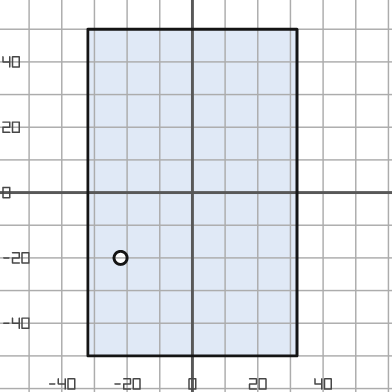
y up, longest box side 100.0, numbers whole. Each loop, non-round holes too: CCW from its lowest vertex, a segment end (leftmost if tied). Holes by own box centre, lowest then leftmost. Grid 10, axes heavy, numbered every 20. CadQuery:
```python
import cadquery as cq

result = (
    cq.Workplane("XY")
    .moveTo(-32.0, -50.0)
    .lineTo(32.0, -50.0)
    .lineTo(32.0, 50.0)
    .lineTo(-32.0, 50.0)
    .close()
    .moveTo(-22.0, -20.0)
    .circle(2.0)
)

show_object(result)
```